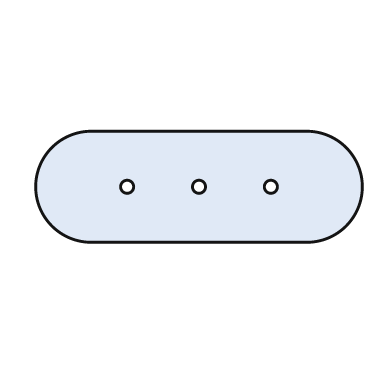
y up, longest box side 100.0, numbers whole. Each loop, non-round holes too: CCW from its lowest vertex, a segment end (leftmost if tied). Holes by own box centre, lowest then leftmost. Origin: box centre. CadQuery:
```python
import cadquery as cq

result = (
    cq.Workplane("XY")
    .moveTo(-33.0, -17.0)
    .lineTo(33.0, -17.0)
    .threePointArc((50.0, 0.0), (33.0, 17.0))
    .lineTo(-33.0, 17.0)
    .threePointArc((-50.0, 0.0), (-33.0, -17.0))
    .close()
    .moveTo(-22.0, 0.0)
    .circle(2.0)
    .moveTo(0.0, 0.0)
    .circle(2.0)
    .moveTo(22.0, 0.0)
    .circle(2.0)
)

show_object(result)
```